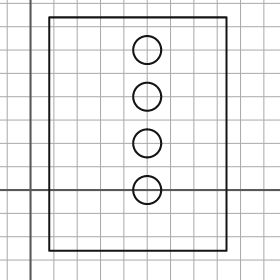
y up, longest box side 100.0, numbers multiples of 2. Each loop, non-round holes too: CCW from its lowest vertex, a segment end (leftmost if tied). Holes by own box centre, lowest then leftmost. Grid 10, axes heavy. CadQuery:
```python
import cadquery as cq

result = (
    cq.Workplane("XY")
    .moveTo(8.0, -26.0)
    .lineTo(84.0, -26.0)
    .lineTo(84.0, 74.0)
    .lineTo(8.0, 74.0)
    .close()
    .moveTo(50.0, 0.0)
    .circle(6.0)
    .moveTo(50.0, 20.0)
    .circle(6.0)
    .moveTo(50.0, 40.0)
    .circle(6.0)
    .moveTo(50.0, 60.0)
    .circle(6.0)
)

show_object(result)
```